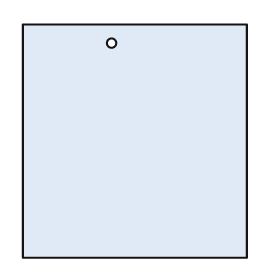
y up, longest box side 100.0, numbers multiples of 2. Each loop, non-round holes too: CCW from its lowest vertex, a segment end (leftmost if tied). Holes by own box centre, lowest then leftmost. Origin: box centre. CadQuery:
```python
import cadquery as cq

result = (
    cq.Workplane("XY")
    .moveTo(-48.0, -50.0)
    .lineTo(48.0, -50.0)
    .lineTo(48.0, 50.0)
    .lineTo(-48.0, 50.0)
    .close()
    .moveTo(-10.0, 42.0)
    .circle(2.0)
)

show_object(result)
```